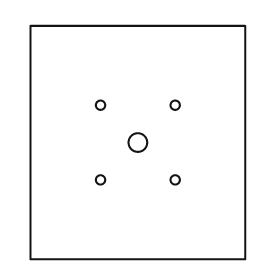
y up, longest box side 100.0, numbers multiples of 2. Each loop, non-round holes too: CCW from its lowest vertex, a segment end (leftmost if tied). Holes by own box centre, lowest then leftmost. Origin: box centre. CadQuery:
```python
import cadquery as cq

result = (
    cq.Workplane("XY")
    .moveTo(-46.0, -50.0)
    .lineTo(46.0, -50.0)
    .lineTo(46.0, 50.0)
    .lineTo(-46.0, 50.0)
    .close()
    .moveTo(-16.0, -16.0)
    .circle(2.0)
    .moveTo(16.0, -16.0)
    .circle(2.0)
    .moveTo(0.0, 0.0)
    .circle(4.0)
    .moveTo(-16.0, 16.0)
    .circle(2.0)
    .moveTo(16.0, 16.0)
    .circle(2.0)
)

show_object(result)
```